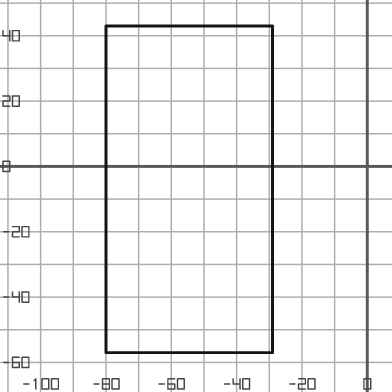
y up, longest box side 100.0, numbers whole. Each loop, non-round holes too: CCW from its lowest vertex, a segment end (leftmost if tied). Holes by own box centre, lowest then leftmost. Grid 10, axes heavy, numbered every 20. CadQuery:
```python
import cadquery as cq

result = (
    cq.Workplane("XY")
    .moveTo(-80.0, -57.0)
    .lineTo(-29.0, -57.0)
    .lineTo(-29.0, 43.0)
    .lineTo(-80.0, 43.0)
    .close()
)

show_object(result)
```